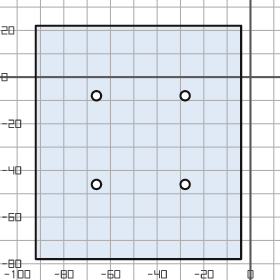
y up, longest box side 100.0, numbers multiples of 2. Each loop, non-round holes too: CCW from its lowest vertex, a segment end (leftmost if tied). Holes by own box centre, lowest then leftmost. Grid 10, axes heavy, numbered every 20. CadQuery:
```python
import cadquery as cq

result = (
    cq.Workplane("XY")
    .moveTo(-92.0, -78.0)
    .lineTo(-4.0, -78.0)
    .lineTo(-4.0, 22.0)
    .lineTo(-92.0, 22.0)
    .close()
    .moveTo(-66.0, -46.0)
    .circle(2.0)
    .moveTo(-28.0, -46.0)
    .circle(2.0)
    .moveTo(-66.0, -8.0)
    .circle(2.0)
    .moveTo(-28.0, -8.0)
    .circle(2.0)
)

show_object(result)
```